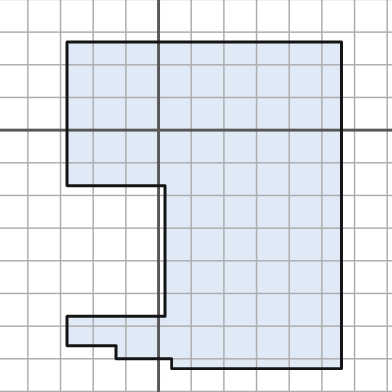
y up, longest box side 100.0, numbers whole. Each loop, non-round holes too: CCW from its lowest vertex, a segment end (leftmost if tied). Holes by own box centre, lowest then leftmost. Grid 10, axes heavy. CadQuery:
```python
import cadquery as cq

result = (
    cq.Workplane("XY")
    .moveTo(4.0, -73.0)
    .lineTo(56.0, -73.0)
    .lineTo(56.0, 27.0)
    .lineTo(-28.0, 27.0)
    .lineTo(-28.0, -17.0)
    .lineTo(2.0, -17.0)
    .lineTo(2.0, -57.0)
    .lineTo(-28.0, -57.0)
    .lineTo(-28.0, -66.0)
    .lineTo(-13.0, -66.0)
    .lineTo(-13.0, -70.0)
    .lineTo(4.0, -70.0)
    .close()
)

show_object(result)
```